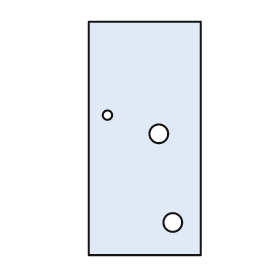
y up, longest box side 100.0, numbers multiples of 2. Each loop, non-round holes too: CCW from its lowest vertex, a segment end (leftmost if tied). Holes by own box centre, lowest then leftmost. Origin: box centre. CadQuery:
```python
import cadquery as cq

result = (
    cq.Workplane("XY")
    .moveTo(-24.0, -50.0)
    .lineTo(24.0, -50.0)
    .lineTo(24.0, 50.0)
    .lineTo(-24.0, 50.0)
    .close()
    .moveTo(12.0, -36.0)
    .circle(4.0)
    .moveTo(6.0, 2.0)
    .circle(4.0)
    .moveTo(-16.0, 10.0)
    .circle(2.0)
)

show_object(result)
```